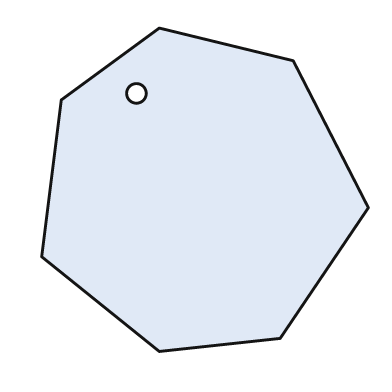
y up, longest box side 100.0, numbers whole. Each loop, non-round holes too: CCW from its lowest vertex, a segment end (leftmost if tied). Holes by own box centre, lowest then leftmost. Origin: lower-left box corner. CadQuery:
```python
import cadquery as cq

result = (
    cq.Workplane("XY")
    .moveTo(36.0, 0.0)
    .lineTo(73.0, 4.0)
    .lineTo(100.0, 44.0)
    .lineTo(77.0, 89.0)
    .lineTo(36.0, 99.0)
    .lineTo(6.0, 77.0)
    .lineTo(0.0, 29.0)
    .close()
    .moveTo(29.0, 79.0)
    .circle(3.0)
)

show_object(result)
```